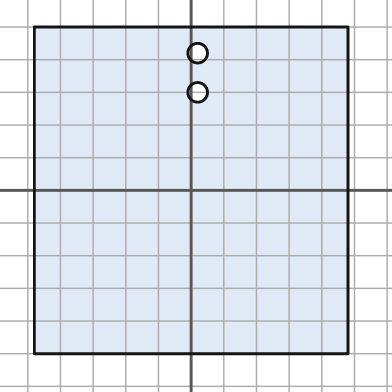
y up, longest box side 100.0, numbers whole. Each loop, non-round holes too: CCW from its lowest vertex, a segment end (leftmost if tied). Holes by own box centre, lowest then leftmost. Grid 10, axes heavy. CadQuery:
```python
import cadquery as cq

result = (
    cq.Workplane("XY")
    .moveTo(-48.0, -50.0)
    .lineTo(48.0, -50.0)
    .lineTo(48.0, 50.0)
    .lineTo(-48.0, 50.0)
    .close()
    .moveTo(2.0, 30.0)
    .circle(3.0)
    .moveTo(2.0, 42.0)
    .circle(3.0)
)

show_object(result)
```